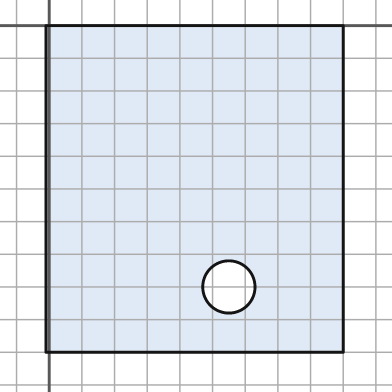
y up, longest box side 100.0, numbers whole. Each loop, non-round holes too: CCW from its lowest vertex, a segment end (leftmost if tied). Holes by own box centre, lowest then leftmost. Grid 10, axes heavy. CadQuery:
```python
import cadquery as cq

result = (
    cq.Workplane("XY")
    .moveTo(-1.0, -100.0)
    .lineTo(90.0, -100.0)
    .lineTo(90.0, 0.0)
    .lineTo(-1.0, 0.0)
    .close()
    .moveTo(55.0, -80.0)
    .circle(8.0)
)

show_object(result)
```